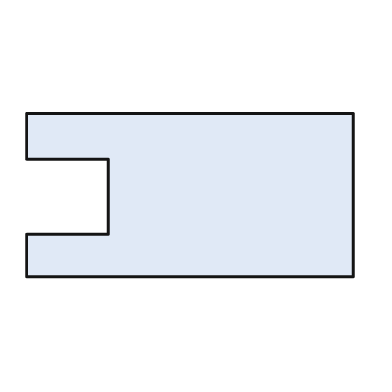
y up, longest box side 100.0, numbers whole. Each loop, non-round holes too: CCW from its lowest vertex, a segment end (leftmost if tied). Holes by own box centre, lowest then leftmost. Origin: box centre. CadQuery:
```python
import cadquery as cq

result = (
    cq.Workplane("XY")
    .moveTo(-50.0, -25.0)
    .lineTo(50.0, -25.0)
    .lineTo(50.0, 25.0)
    .lineTo(-50.0, 25.0)
    .lineTo(-50.0, 11.0)
    .lineTo(-25.0, 11.0)
    .lineTo(-25.0, -12.0)
    .lineTo(-50.0, -12.0)
    .close()
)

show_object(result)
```